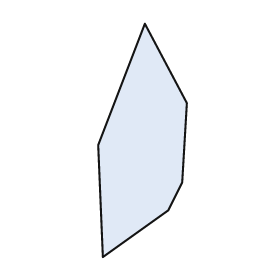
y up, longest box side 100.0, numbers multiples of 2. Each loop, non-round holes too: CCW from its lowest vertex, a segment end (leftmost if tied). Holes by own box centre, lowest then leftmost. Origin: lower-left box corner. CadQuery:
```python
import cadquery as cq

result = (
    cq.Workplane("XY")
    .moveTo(2.0, 0.0)
    .lineTo(30.0, 20.0)
    .lineTo(36.0, 32.0)
    .lineTo(38.0, 66.0)
    .lineTo(20.0, 100.0)
    .lineTo(0.0, 48.0)
    .close()
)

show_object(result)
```